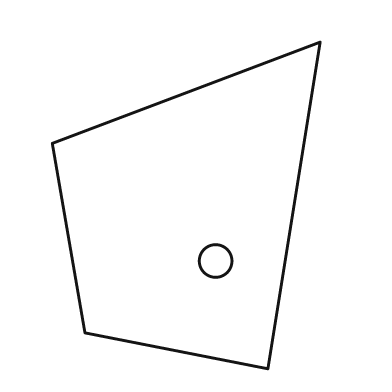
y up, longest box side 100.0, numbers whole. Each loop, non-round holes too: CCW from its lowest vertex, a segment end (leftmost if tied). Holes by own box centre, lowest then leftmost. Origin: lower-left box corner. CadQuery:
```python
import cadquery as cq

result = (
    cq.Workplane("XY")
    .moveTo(66.0, 0.0)
    .lineTo(82.0, 100.0)
    .lineTo(0.0, 69.0)
    .lineTo(10.0, 11.0)
    .close()
    .moveTo(50.0, 33.0)
    .circle(5.0)
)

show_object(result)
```